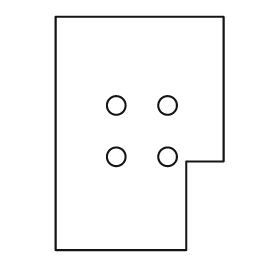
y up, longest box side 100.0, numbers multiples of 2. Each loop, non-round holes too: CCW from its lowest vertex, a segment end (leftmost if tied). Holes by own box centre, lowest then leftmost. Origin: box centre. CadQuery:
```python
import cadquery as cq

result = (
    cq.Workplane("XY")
    .moveTo(-36.0, -50.0)
    .lineTo(20.0, -50.0)
    .lineTo(20.0, -12.0)
    .lineTo(36.0, -12.0)
    .lineTo(36.0, 50.0)
    .lineTo(-36.0, 50.0)
    .close()
    .moveTo(-10.0, -10.0)
    .circle(4.0)
    .moveTo(12.0, -10.0)
    .circle(4.0)
    .moveTo(-10.0, 12.0)
    .circle(4.0)
    .moveTo(12.0, 12.0)
    .circle(4.0)
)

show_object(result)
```